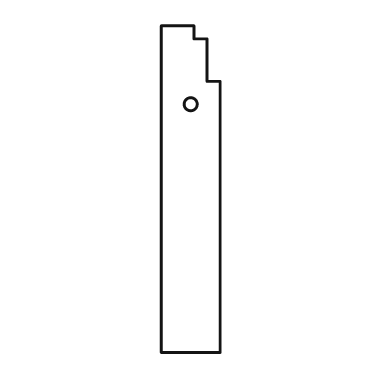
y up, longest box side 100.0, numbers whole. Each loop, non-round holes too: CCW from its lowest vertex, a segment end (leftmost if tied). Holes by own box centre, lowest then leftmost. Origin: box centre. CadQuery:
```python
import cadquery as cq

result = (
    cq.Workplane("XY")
    .moveTo(-9.0, -50.0)
    .lineTo(9.0, -50.0)
    .lineTo(9.0, 33.0)
    .lineTo(5.0, 33.0)
    .lineTo(5.0, 46.0)
    .lineTo(1.0, 46.0)
    .lineTo(1.0, 50.0)
    .lineTo(-9.0, 50.0)
    .close()
    .moveTo(0.0, 26.0)
    .circle(2.0)
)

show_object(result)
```